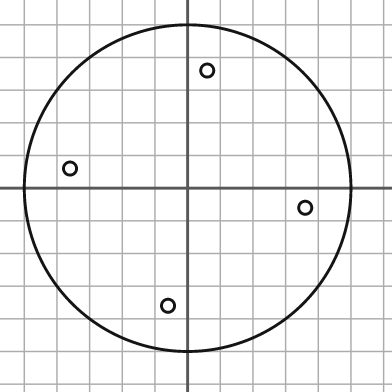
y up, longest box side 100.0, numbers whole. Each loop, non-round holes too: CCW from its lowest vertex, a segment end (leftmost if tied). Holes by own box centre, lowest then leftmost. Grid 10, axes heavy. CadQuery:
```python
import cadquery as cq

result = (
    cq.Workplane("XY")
    .moveTo(0.0, 0.0)
    .circle(50.0)
    .moveTo(-6.0, -36.0)
    .circle(2.0)
    .moveTo(36.0, -6.0)
    .circle(2.0)
    .moveTo(-36.0, 6.0)
    .circle(2.0)
    .moveTo(6.0, 36.0)
    .circle(2.0)
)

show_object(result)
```